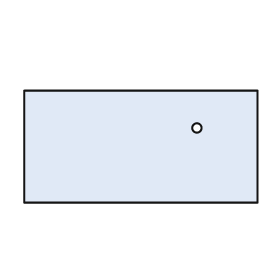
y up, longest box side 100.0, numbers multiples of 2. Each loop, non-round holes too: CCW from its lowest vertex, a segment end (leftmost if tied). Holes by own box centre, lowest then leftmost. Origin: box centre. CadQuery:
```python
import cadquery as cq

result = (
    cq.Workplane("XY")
    .moveTo(-50.0, -24.0)
    .lineTo(50.0, -24.0)
    .lineTo(50.0, 24.0)
    .lineTo(-50.0, 24.0)
    .close()
    .moveTo(24.0, 8.0)
    .circle(2.0)
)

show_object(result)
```